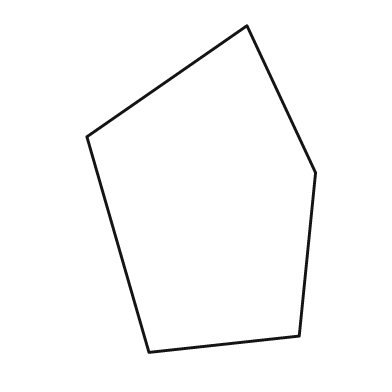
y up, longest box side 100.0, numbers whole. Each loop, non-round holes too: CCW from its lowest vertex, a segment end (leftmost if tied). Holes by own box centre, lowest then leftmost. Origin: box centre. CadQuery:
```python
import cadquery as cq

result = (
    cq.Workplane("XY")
    .moveTo(-16.0, -50.0)
    .lineTo(30.0, -45.0)
    .lineTo(35.0, 5.0)
    .lineTo(14.0, 50.0)
    .lineTo(-35.0, 16.0)
    .close()
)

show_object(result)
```